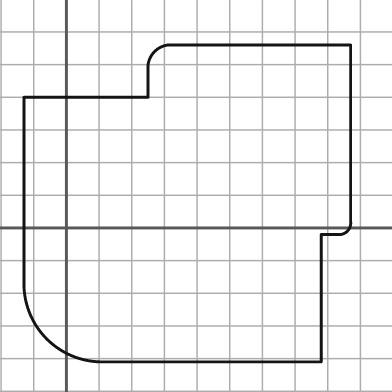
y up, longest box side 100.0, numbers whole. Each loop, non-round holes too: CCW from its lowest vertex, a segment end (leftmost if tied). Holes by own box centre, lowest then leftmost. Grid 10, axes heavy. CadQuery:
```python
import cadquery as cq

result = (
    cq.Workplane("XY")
    .moveTo(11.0, -41.0)
    .lineTo(78.0, -41.0)
    .lineTo(78.0, -2.0)
    .lineTo(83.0, -2.0)
    .threePointArc((86.0, -1.0), (87.0, 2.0))
    .lineTo(87.0, 56.0)
    .lineTo(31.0, 56.0)
    .threePointArc((27.0, 54.0), (25.0, 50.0))
    .lineTo(25.0, 40.0)
    .lineTo(-13.0, 40.0)
    .lineTo(-13.0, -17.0)
    .threePointArc((-6.0, -34.0), (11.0, -41.0))
    .close()
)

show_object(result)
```